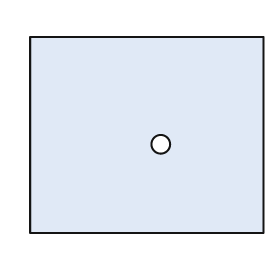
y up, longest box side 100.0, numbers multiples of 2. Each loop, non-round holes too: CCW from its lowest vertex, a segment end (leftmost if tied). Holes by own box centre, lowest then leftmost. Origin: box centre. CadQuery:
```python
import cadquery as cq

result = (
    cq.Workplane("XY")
    .moveTo(-50.0, -42.0)
    .lineTo(50.0, -42.0)
    .lineTo(50.0, 42.0)
    .lineTo(-50.0, 42.0)
    .close()
    .moveTo(6.0, -4.0)
    .circle(4.0)
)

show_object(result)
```